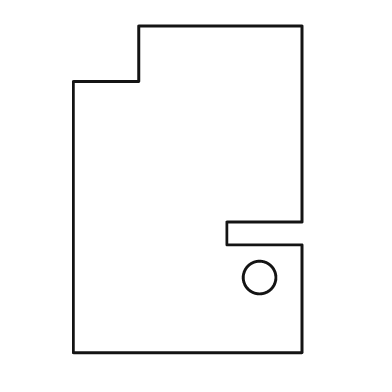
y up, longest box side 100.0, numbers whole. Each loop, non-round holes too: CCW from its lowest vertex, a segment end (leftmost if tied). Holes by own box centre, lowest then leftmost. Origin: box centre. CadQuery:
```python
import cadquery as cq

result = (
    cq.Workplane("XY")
    .moveTo(-35.0, -50.0)
    .lineTo(35.0, -50.0)
    .lineTo(35.0, -17.0)
    .lineTo(12.0, -17.0)
    .lineTo(12.0, -10.0)
    .lineTo(35.0, -10.0)
    .lineTo(35.0, 50.0)
    .lineTo(-15.0, 50.0)
    .lineTo(-15.0, 33.0)
    .lineTo(-35.0, 33.0)
    .close()
    .moveTo(22.0, -27.0)
    .circle(5.0)
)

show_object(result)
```